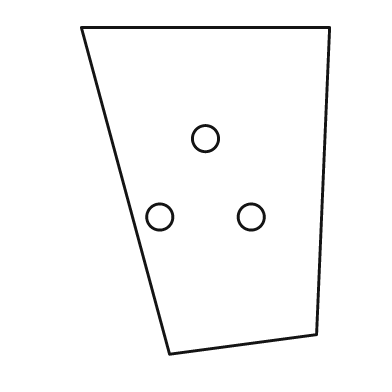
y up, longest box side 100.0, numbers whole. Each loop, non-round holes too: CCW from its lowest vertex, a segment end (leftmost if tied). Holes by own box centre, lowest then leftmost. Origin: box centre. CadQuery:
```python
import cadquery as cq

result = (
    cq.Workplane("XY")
    .moveTo(-11.0, -50.0)
    .lineTo(34.0, -44.0)
    .lineTo(38.0, 50.0)
    .lineTo(-38.0, 50.0)
    .close()
    .moveTo(-14.0, -8.0)
    .circle(4.0)
    .moveTo(14.0, -8.0)
    .circle(4.0)
    .moveTo(0.0, 16.0)
    .circle(4.0)
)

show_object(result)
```